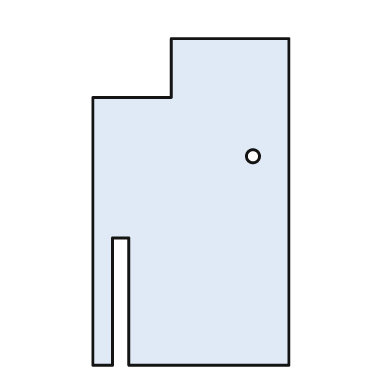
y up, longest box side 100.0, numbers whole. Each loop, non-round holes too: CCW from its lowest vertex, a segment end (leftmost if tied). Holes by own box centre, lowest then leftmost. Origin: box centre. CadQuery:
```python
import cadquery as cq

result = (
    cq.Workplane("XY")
    .moveTo(-30.0, -50.0)
    .lineTo(-24.0, -50.0)
    .lineTo(-24.0, -11.0)
    .lineTo(-19.0, -11.0)
    .lineTo(-19.0, -50.0)
    .lineTo(30.0, -50.0)
    .lineTo(30.0, 50.0)
    .lineTo(-6.0, 50.0)
    .lineTo(-6.0, 32.0)
    .lineTo(-30.0, 32.0)
    .close()
    .moveTo(19.0, 14.0)
    .circle(2.0)
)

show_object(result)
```